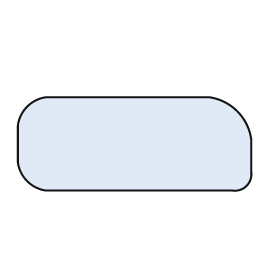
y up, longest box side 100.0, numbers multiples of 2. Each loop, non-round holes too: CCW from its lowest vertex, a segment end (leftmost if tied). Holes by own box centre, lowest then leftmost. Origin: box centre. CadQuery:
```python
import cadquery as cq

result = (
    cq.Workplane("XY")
    .moveTo(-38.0, -20.0)
    .lineTo(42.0, -20.0)
    .threePointArc((48.0, -18.0), (50.0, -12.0))
    .lineTo(50.0, 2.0)
    .threePointArc((44.0, 14.0), (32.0, 20.0))
    .lineTo(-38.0, 20.0)
    .threePointArc((-46.0, 16.0), (-50.0, 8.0))
    .lineTo(-50.0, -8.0)
    .threePointArc((-46.0, -16.0), (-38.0, -20.0))
    .close()
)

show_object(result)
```